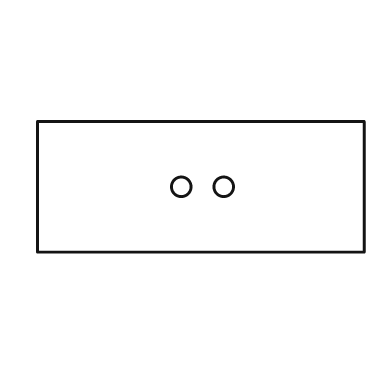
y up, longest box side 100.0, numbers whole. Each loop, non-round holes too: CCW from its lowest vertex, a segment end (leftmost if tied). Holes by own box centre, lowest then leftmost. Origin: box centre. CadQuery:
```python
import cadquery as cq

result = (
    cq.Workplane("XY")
    .moveTo(-50.0, -20.0)
    .lineTo(50.0, -20.0)
    .lineTo(50.0, 20.0)
    .lineTo(-50.0, 20.0)
    .close()
    .moveTo(-6.0, 0.0)
    .circle(3.0)
    .moveTo(7.0, 0.0)
    .circle(3.0)
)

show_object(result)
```